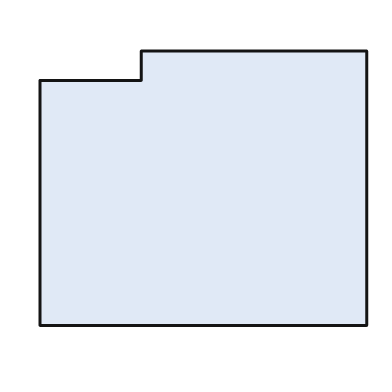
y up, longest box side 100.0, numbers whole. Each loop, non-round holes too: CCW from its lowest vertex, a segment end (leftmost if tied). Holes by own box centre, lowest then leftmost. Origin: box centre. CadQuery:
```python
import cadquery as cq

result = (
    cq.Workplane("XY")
    .moveTo(-50.0, -42.0)
    .lineTo(50.0, -42.0)
    .lineTo(50.0, 42.0)
    .lineTo(-19.0, 42.0)
    .lineTo(-19.0, 33.0)
    .lineTo(-50.0, 33.0)
    .close()
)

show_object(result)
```